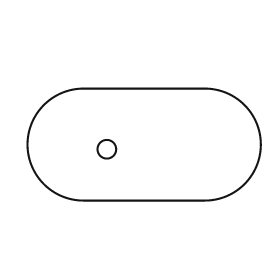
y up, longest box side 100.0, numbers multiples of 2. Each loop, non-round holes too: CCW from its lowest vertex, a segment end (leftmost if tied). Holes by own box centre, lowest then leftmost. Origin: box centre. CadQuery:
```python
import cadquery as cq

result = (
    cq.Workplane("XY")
    .moveTo(-26.0, -24.0)
    .lineTo(26.0, -24.0)
    .threePointArc((50.0, 0.0), (26.0, 24.0))
    .lineTo(-26.0, 24.0)
    .threePointArc((-50.0, 0.0), (-26.0, -24.0))
    .close()
    .moveTo(-16.0, -2.0)
    .circle(4.0)
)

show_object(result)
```